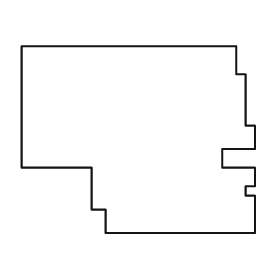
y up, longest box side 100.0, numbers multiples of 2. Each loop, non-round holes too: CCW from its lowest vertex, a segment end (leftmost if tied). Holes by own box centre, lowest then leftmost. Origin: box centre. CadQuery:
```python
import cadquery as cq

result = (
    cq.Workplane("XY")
    .moveTo(-14.0, -40.0)
    .lineTo(50.0, -40.0)
    .lineTo(50.0, -24.0)
    .lineTo(46.0, -24.0)
    .lineTo(46.0, -20.0)
    .lineTo(50.0, -20.0)
    .lineTo(50.0, -12.0)
    .lineTo(36.0, -12.0)
    .lineTo(36.0, -4.0)
    .lineTo(50.0, -4.0)
    .lineTo(50.0, 6.0)
    .lineTo(46.0, 6.0)
    .lineTo(46.0, 28.0)
    .lineTo(42.0, 28.0)
    .lineTo(42.0, 40.0)
    .lineTo(-50.0, 40.0)
    .lineTo(-50.0, -12.0)
    .lineTo(-20.0, -12.0)
    .lineTo(-20.0, -30.0)
    .lineTo(-14.0, -30.0)
    .close()
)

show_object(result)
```